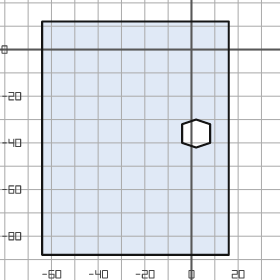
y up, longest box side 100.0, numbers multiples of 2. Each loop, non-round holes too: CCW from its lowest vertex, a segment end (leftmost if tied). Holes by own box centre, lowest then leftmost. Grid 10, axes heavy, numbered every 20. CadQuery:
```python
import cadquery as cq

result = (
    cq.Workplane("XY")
    .moveTo(-64.0, -88.0)
    .lineTo(16.0, -88.0)
    .lineTo(16.0, 12.0)
    .lineTo(-64.0, 12.0)
    .close()
    .moveTo(2.0, -42.0)
    .lineTo(8.0, -40.0)
    .lineTo(8.0, -32.0)
    .lineTo(2.0, -30.0)
    .lineTo(-4.0, -32.0)
    .lineTo(-4.0, -40.0)
    .close()
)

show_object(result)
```